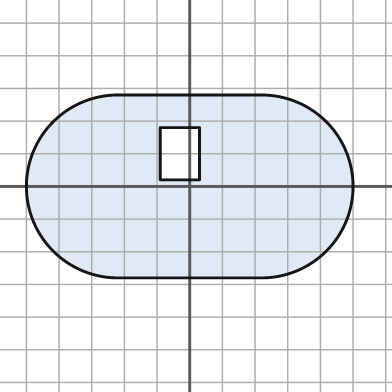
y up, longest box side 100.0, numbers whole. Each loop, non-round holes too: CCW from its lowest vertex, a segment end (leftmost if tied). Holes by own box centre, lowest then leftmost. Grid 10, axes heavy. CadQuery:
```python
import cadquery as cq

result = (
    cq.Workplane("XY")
    .moveTo(-22.0, -28.0)
    .lineTo(22.0, -28.0)
    .threePointArc((50.0, 0.0), (22.0, 28.0))
    .lineTo(-22.0, 28.0)
    .threePointArc((-50.0, 0.0), (-22.0, -28.0))
    .close()
    .moveTo(-9.0, 2.0)
    .lineTo(3.0, 2.0)
    .lineTo(3.0, 18.0)
    .lineTo(-9.0, 18.0)
    .close()
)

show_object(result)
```